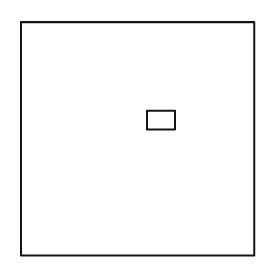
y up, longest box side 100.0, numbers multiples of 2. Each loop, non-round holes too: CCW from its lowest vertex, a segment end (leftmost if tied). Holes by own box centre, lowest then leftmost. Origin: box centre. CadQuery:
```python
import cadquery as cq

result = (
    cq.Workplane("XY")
    .moveTo(-50.0, -50.0)
    .lineTo(50.0, -50.0)
    .lineTo(50.0, 50.0)
    .lineTo(-50.0, 50.0)
    .close()
    .moveTo(4.0, 4.0)
    .lineTo(16.0, 4.0)
    .lineTo(16.0, 12.0)
    .lineTo(4.0, 12.0)
    .close()
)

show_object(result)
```